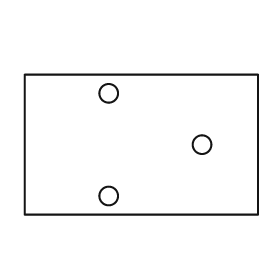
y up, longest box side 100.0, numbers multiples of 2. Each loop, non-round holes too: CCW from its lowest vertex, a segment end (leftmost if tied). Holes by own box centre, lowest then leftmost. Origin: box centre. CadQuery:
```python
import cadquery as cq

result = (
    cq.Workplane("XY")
    .moveTo(-50.0, -30.0)
    .lineTo(50.0, -30.0)
    .lineTo(50.0, 30.0)
    .lineTo(-50.0, 30.0)
    .close()
    .moveTo(-14.0, -22.0)
    .circle(4.0)
    .moveTo(26.0, 0.0)
    .circle(4.0)
    .moveTo(-14.0, 22.0)
    .circle(4.0)
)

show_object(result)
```